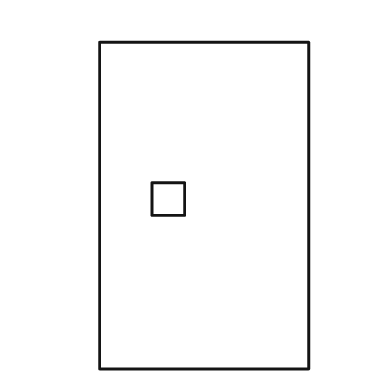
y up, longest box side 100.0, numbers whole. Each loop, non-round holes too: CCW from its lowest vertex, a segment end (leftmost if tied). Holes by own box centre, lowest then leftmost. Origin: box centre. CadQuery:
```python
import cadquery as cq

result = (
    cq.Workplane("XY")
    .moveTo(-32.0, -50.0)
    .lineTo(32.0, -50.0)
    .lineTo(32.0, 50.0)
    .lineTo(-32.0, 50.0)
    .close()
    .moveTo(-16.0, -3.0)
    .lineTo(-6.0, -3.0)
    .lineTo(-6.0, 7.0)
    .lineTo(-16.0, 7.0)
    .close()
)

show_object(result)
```